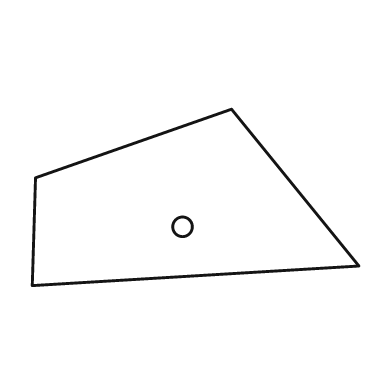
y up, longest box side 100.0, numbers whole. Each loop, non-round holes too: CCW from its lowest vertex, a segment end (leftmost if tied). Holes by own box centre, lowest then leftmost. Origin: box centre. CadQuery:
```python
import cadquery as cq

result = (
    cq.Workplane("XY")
    .moveTo(-50.0, -27.0)
    .lineTo(50.0, -21.0)
    .lineTo(11.0, 27.0)
    .lineTo(-49.0, 6.0)
    .close()
    .moveTo(-4.0, -9.0)
    .circle(3.0)
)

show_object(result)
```